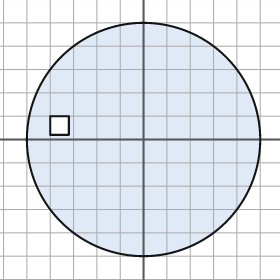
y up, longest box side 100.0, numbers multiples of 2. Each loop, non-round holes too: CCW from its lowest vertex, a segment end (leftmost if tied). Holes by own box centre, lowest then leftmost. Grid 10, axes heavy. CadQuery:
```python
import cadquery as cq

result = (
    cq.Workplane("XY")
    .moveTo(0.0, 0.0)
    .circle(50.0)
    .moveTo(-40.0, 2.0)
    .lineTo(-32.0, 2.0)
    .lineTo(-32.0, 10.0)
    .lineTo(-40.0, 10.0)
    .close()
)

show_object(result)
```